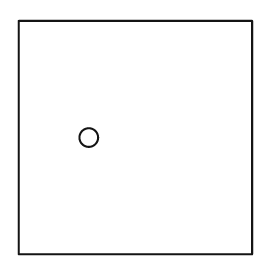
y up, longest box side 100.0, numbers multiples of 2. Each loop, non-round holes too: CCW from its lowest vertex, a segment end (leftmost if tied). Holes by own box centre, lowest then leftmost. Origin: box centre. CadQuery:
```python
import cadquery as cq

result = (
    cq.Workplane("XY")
    .moveTo(-50.0, -50.0)
    .lineTo(50.0, -50.0)
    .lineTo(50.0, 50.0)
    .lineTo(-50.0, 50.0)
    .close()
    .moveTo(-20.0, 0.0)
    .circle(4.0)
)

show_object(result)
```